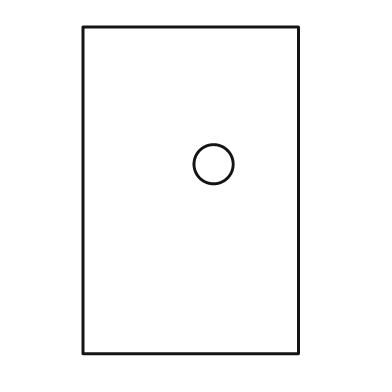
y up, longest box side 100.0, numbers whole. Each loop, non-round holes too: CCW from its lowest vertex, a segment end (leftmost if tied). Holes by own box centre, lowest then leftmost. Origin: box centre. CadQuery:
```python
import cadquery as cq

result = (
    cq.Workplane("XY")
    .moveTo(-33.0, -50.0)
    .lineTo(33.0, -50.0)
    .lineTo(33.0, 50.0)
    .lineTo(-33.0, 50.0)
    .close()
    .moveTo(7.0, 8.0)
    .circle(6.0)
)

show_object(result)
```